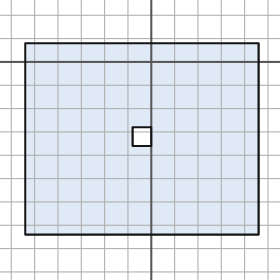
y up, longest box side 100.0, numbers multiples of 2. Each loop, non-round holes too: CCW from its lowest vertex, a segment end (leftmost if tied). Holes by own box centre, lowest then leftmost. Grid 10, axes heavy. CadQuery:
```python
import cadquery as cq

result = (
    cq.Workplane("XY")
    .moveTo(-54.0, -74.0)
    .lineTo(46.0, -74.0)
    .lineTo(46.0, 8.0)
    .lineTo(-54.0, 8.0)
    .close()
    .moveTo(-8.0, -36.0)
    .lineTo(0.0, -36.0)
    .lineTo(0.0, -28.0)
    .lineTo(-8.0, -28.0)
    .close()
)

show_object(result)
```